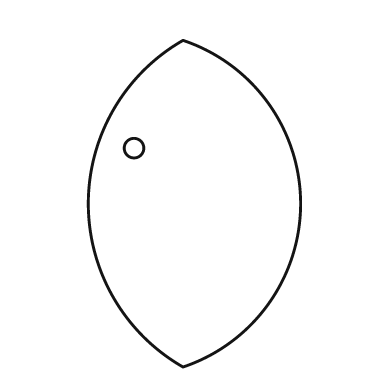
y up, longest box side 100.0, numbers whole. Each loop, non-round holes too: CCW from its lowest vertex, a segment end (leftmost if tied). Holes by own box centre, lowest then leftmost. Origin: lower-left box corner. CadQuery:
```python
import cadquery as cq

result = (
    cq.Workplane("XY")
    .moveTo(29.0, 0.0)
    .threePointArc((65.0, 50.0), (29.0, 100.0))
    .threePointArc((0.0, 50.0), (29.0, 0.0))
    .close()
    .moveTo(14.0, 67.0)
    .circle(3.0)
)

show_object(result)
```